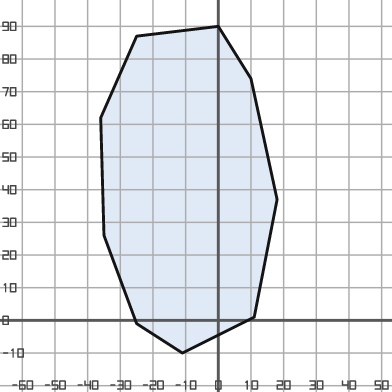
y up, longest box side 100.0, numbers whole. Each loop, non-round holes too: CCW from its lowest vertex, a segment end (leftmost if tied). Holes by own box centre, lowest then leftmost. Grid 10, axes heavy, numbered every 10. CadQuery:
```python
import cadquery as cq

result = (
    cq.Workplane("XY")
    .moveTo(-11.0, -10.0)
    .lineTo(11.0, 1.0)
    .lineTo(18.0, 37.0)
    .lineTo(10.0, 74.0)
    .lineTo(0.0, 90.0)
    .lineTo(-25.0, 87.0)
    .lineTo(-36.0, 62.0)
    .lineTo(-35.0, 26.0)
    .lineTo(-25.0, -1.0)
    .close()
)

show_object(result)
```